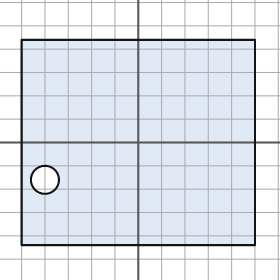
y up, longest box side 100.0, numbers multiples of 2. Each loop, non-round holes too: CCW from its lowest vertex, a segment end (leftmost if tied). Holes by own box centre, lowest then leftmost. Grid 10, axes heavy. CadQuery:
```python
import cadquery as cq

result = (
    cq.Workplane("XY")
    .moveTo(-50.0, -44.0)
    .lineTo(50.0, -44.0)
    .lineTo(50.0, 44.0)
    .lineTo(-50.0, 44.0)
    .close()
    .moveTo(-40.0, -16.0)
    .circle(6.0)
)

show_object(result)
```